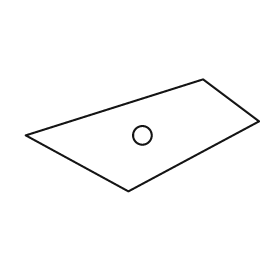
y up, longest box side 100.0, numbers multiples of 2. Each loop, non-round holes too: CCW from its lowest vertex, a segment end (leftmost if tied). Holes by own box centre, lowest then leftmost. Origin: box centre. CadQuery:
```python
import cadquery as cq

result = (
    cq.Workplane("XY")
    .moveTo(-6.0, -24.0)
    .lineTo(50.0, 6.0)
    .lineTo(26.0, 24.0)
    .lineTo(-50.0, 0.0)
    .close()
    .moveTo(0.0, 0.0)
    .circle(4.0)
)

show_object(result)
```